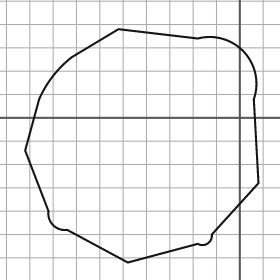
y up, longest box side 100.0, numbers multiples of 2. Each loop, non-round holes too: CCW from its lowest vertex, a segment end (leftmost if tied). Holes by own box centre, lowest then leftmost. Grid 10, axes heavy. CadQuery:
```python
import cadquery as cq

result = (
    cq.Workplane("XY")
    .moveTo(-48.0, -62.0)
    .lineTo(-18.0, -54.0)
    .threePointArc((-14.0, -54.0), (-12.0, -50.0))
    .lineTo(8.0, -28.0)
    .lineTo(6.0, 8.0)
    .threePointArc((2.0, 28.0), (-18.0, 34.0))
    .lineTo(-52.0, 38.0)
    .lineTo(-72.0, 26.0)
    .threePointArc((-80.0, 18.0), (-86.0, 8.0))
    .lineTo(-92.0, -14.0)
    .lineTo(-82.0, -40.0)
    .threePointArc((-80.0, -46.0), (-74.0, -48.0))
    .close()
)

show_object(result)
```